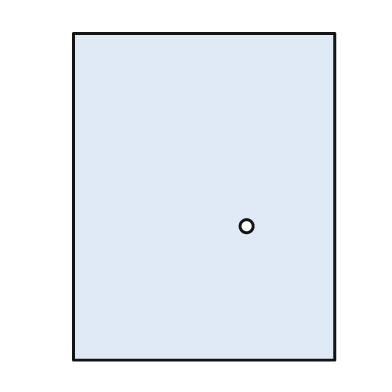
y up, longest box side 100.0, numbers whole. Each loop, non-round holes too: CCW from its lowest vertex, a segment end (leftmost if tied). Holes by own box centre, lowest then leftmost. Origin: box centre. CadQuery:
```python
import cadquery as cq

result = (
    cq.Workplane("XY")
    .moveTo(-40.0, -50.0)
    .lineTo(40.0, -50.0)
    .lineTo(40.0, 50.0)
    .lineTo(-40.0, 50.0)
    .close()
    .moveTo(13.0, -9.0)
    .circle(2.0)
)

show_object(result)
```